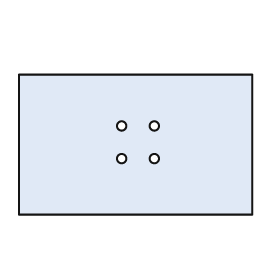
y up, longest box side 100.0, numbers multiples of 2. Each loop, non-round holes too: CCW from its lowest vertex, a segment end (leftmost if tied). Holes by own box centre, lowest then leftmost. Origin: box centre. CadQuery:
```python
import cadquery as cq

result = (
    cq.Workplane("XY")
    .moveTo(-50.0, -30.0)
    .lineTo(50.0, -30.0)
    .lineTo(50.0, 30.0)
    .lineTo(-50.0, 30.0)
    .close()
    .moveTo(-6.0, -6.0)
    .circle(2.0)
    .moveTo(8.0, -6.0)
    .circle(2.0)
    .moveTo(-6.0, 8.0)
    .circle(2.0)
    .moveTo(8.0, 8.0)
    .circle(2.0)
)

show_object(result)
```